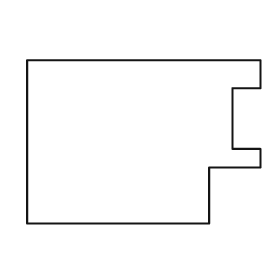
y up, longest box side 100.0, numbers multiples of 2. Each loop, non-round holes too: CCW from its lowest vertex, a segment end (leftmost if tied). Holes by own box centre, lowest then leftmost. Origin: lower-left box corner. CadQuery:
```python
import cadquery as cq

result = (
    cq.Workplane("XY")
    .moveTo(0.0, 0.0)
    .lineTo(78.0, 0.0)
    .lineTo(78.0, 24.0)
    .lineTo(100.0, 24.0)
    .lineTo(100.0, 32.0)
    .lineTo(88.0, 32.0)
    .lineTo(88.0, 58.0)
    .lineTo(100.0, 58.0)
    .lineTo(100.0, 70.0)
    .lineTo(0.0, 70.0)
    .close()
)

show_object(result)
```